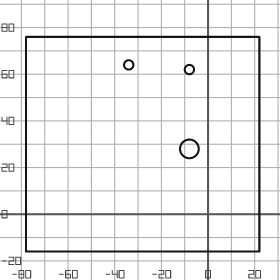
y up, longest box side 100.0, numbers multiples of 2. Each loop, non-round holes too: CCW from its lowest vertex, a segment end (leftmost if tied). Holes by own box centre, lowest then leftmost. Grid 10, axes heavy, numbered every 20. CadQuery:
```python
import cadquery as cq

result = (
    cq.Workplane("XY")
    .moveTo(-78.0, -16.0)
    .lineTo(22.0, -16.0)
    .lineTo(22.0, 76.0)
    .lineTo(-78.0, 76.0)
    .close()
    .moveTo(-8.0, 28.0)
    .circle(4.0)
    .moveTo(-8.0, 62.0)
    .circle(2.0)
    .moveTo(-34.0, 64.0)
    .circle(2.0)
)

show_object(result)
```